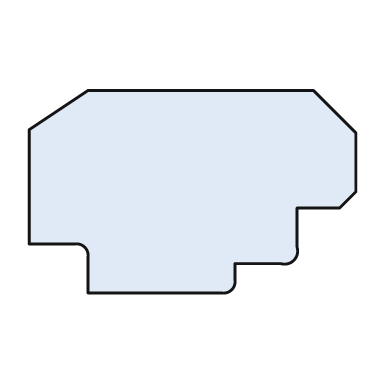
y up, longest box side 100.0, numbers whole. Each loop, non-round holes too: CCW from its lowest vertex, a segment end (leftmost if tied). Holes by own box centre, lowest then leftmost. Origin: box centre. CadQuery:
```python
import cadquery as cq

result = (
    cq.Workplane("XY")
    .moveTo(-32.0, -31.0)
    .lineTo(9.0, -31.0)
    .threePointArc((12.0, -30.0), (13.0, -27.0))
    .lineTo(13.0, -22.0)
    .lineTo(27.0, -22.0)
    .threePointArc((31.0, -21.0), (32.0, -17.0))
    .lineTo(32.0, -5.0)
    .lineTo(45.0, -5.0)
    .lineTo(50.0, 0.0)
    .lineTo(50.0, 18.0)
    .lineTo(37.0, 31.0)
    .lineTo(-32.0, 31.0)
    .lineTo(-50.0, 19.0)
    .lineTo(-50.0, -16.0)
    .lineTo(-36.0, -16.0)
    .threePointArc((-33.0, -17.0), (-32.0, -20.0))
    .close()
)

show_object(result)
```